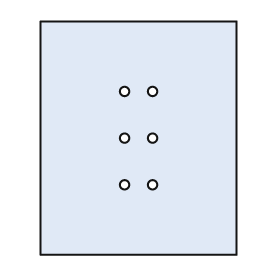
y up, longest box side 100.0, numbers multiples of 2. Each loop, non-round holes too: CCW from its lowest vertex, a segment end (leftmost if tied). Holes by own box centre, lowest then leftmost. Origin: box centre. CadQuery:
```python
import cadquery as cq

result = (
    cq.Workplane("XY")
    .moveTo(-42.0, -50.0)
    .lineTo(42.0, -50.0)
    .lineTo(42.0, 50.0)
    .lineTo(-42.0, 50.0)
    .close()
    .moveTo(-6.0, -20.0)
    .circle(2.0)
    .moveTo(6.0, -20.0)
    .circle(2.0)
    .moveTo(-6.0, 0.0)
    .circle(2.0)
    .moveTo(6.0, 0.0)
    .circle(2.0)
    .moveTo(-6.0, 20.0)
    .circle(2.0)
    .moveTo(6.0, 20.0)
    .circle(2.0)
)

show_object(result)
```